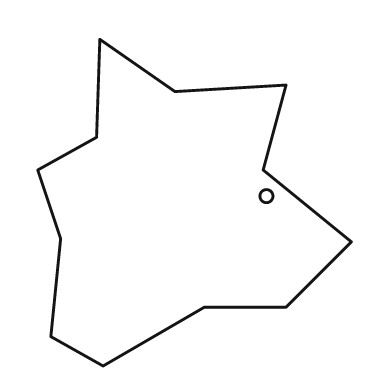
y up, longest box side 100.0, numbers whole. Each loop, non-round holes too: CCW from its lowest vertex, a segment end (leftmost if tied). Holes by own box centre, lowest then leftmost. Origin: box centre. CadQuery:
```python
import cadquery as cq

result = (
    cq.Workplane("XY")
    .moveTo(-28.0, -50.0)
    .lineTo(3.0, -32.0)
    .lineTo(28.0, -32.0)
    .lineTo(48.0, -12.0)
    .lineTo(21.0, 10.0)
    .lineTo(28.0, 36.0)
    .lineTo(-6.0, 34.0)
    .lineTo(-29.0, 50.0)
    .lineTo(-30.0, 20.0)
    .lineTo(-48.0, 10.0)
    .lineTo(-41.0, -11.0)
    .lineTo(-44.0, -41.0)
    .close()
    .moveTo(22.0, 2.0)
    .circle(2.0)
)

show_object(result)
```